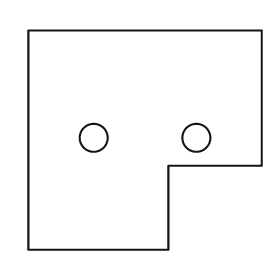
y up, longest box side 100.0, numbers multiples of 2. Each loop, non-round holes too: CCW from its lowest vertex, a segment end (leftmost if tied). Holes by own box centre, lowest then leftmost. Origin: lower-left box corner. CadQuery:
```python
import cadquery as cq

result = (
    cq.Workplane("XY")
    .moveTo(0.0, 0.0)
    .lineTo(60.0, 0.0)
    .lineTo(60.0, 36.0)
    .lineTo(100.0, 36.0)
    .lineTo(100.0, 94.0)
    .lineTo(0.0, 94.0)
    .close()
    .moveTo(28.0, 48.0)
    .circle(6.0)
    .moveTo(72.0, 48.0)
    .circle(6.0)
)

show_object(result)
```